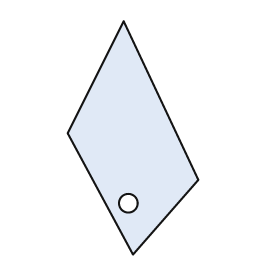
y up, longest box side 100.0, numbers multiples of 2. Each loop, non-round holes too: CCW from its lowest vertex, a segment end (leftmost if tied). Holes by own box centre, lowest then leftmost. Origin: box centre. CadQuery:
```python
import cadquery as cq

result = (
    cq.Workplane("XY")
    .moveTo(0.0, -50.0)
    .lineTo(28.0, -18.0)
    .lineTo(-4.0, 50.0)
    .lineTo(-28.0, 2.0)
    .close()
    .moveTo(-2.0, -28.0)
    .circle(4.0)
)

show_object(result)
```